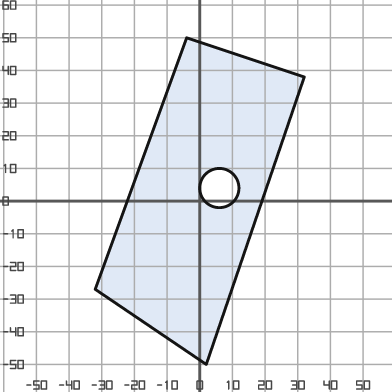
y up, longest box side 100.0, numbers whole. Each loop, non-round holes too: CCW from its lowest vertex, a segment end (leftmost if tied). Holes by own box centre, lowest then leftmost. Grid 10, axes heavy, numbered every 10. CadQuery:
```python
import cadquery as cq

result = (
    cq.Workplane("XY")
    .moveTo(2.0, -50.0)
    .lineTo(32.0, 38.0)
    .lineTo(-4.0, 50.0)
    .lineTo(-32.0, -27.0)
    .close()
    .moveTo(6.0, 4.0)
    .circle(6.0)
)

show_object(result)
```